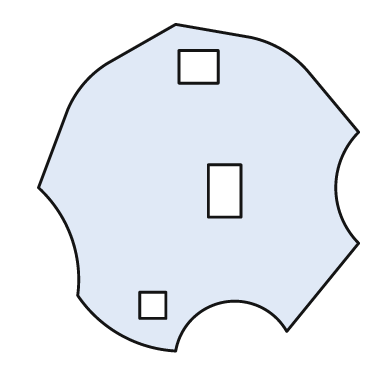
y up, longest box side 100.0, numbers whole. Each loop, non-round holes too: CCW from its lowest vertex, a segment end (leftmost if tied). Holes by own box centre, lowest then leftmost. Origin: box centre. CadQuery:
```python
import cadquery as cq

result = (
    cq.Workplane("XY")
    .moveTo(-7.0, -50.0)
    .threePointArc((8.0, -35.0), (27.0, -44.0))
    .lineTo(49.0, -17.0)
    .threePointArc((42.0, 0.0), (49.0, 17.0))
    .lineTo(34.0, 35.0)
    .threePointArc((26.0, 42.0), (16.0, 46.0))
    .lineTo(-7.0, 50.0)
    .lineTo(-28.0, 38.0)
    .threePointArc((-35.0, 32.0), (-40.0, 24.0))
    .lineTo(-49.0, 0.0)
    .threePointArc((-39.0, -15.0), (-37.0, -33.0))
    .threePointArc((-24.0, -45.0), (-7.0, -50.0))
    .close()
    .moveTo(-18.0, -40.0)
    .lineTo(-10.0, -40.0)
    .lineTo(-10.0, -32.0)
    .lineTo(-18.0, -32.0)
    .close()
    .moveTo(3.0, -9.0)
    .lineTo(13.0, -9.0)
    .lineTo(13.0, 7.0)
    .lineTo(3.0, 7.0)
    .close()
    .moveTo(-6.0, 32.0)
    .lineTo(6.0, 32.0)
    .lineTo(6.0, 42.0)
    .lineTo(-6.0, 42.0)
    .close()
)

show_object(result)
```